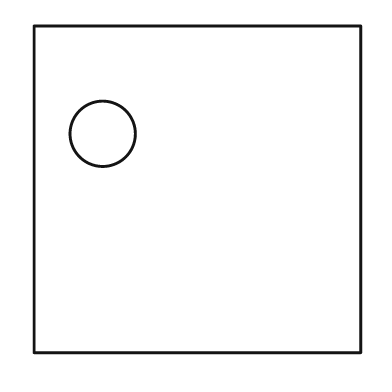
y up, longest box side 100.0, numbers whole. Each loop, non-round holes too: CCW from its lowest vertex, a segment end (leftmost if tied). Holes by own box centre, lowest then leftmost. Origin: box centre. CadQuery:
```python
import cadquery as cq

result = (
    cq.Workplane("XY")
    .moveTo(-50.0, -50.0)
    .lineTo(50.0, -50.0)
    .lineTo(50.0, 50.0)
    .lineTo(-50.0, 50.0)
    .close()
    .moveTo(-29.0, 17.0)
    .circle(10.0)
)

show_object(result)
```